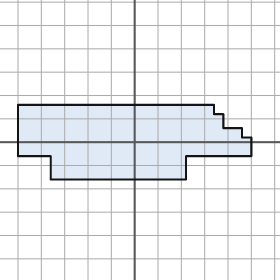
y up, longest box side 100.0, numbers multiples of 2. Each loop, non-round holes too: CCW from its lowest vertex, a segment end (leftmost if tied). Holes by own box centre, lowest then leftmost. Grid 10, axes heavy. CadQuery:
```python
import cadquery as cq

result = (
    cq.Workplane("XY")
    .moveTo(-36.0, -16.0)
    .lineTo(22.0, -16.0)
    .lineTo(22.0, -6.0)
    .lineTo(50.0, -6.0)
    .lineTo(50.0, 2.0)
    .lineTo(46.0, 2.0)
    .lineTo(46.0, 6.0)
    .lineTo(38.0, 6.0)
    .lineTo(38.0, 12.0)
    .lineTo(34.0, 12.0)
    .lineTo(34.0, 16.0)
    .lineTo(-50.0, 16.0)
    .lineTo(-50.0, -6.0)
    .lineTo(-36.0, -6.0)
    .close()
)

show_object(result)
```